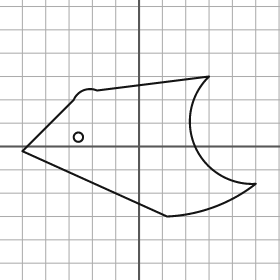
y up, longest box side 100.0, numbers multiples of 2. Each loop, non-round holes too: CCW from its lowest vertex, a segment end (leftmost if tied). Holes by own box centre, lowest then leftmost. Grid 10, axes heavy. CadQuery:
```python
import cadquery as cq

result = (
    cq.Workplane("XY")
    .moveTo(12.0, -30.0)
    .threePointArc((32.0, -26.0), (50.0, -16.0))
    .threePointArc((24.0, 0.0), (30.0, 30.0))
    .lineTo(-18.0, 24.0)
    .threePointArc((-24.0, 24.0), (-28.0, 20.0))
    .lineTo(-50.0, -2.0)
    .close()
    .moveTo(-26.0, 4.0)
    .circle(2.0)
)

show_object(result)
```